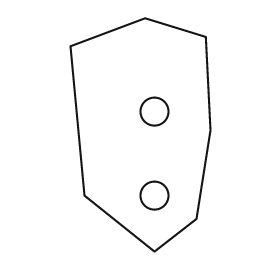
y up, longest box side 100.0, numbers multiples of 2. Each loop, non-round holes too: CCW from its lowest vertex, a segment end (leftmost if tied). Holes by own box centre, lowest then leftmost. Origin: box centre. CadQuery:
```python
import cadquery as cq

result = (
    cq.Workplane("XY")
    .moveTo(6.0, -50.0)
    .lineTo(24.0, -36.0)
    .lineTo(30.0, 2.0)
    .lineTo(28.0, 42.0)
    .lineTo(2.0, 50.0)
    .lineTo(-30.0, 38.0)
    .lineTo(-24.0, -26.0)
    .close()
    .moveTo(6.0, -26.0)
    .circle(6.0)
    .moveTo(6.0, 10.0)
    .circle(6.0)
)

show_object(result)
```